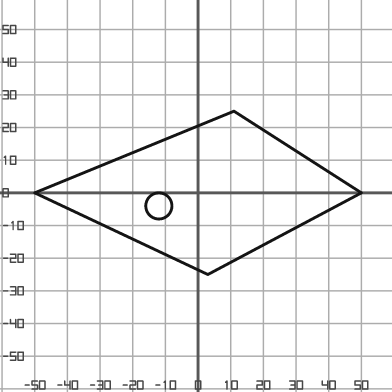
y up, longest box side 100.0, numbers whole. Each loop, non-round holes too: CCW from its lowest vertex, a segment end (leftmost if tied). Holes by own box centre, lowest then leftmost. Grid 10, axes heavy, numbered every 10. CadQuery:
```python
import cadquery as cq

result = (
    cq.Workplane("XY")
    .moveTo(3.0, -25.0)
    .lineTo(50.0, 0.0)
    .lineTo(11.0, 25.0)
    .lineTo(-50.0, 0.0)
    .close()
    .moveTo(-12.0, -4.0)
    .circle(4.0)
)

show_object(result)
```